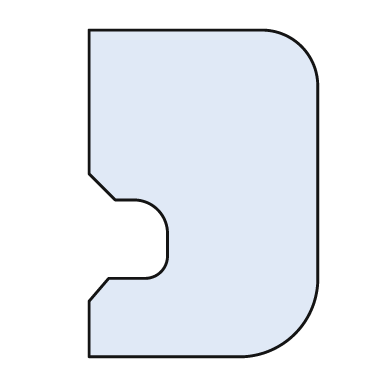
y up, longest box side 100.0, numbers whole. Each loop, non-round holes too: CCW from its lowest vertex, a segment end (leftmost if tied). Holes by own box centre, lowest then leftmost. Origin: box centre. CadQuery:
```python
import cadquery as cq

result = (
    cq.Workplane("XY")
    .moveTo(-35.0, -50.0)
    .lineTo(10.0, -50.0)
    .threePointArc((28.0, -43.0), (35.0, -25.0))
    .lineTo(35.0, 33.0)
    .threePointArc((30.0, 45.0), (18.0, 50.0))
    .lineTo(-35.0, 50.0)
    .lineTo(-35.0, 6.0)
    .lineTo(-27.0, -2.0)
    .lineTo(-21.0, -2.0)
    .threePointArc((-14.0, -5.0), (-11.0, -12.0))
    .lineTo(-11.0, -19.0)
    .threePointArc((-13.0, -24.0), (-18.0, -26.0))
    .lineTo(-29.0, -26.0)
    .lineTo(-35.0, -33.0)
    .close()
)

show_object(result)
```